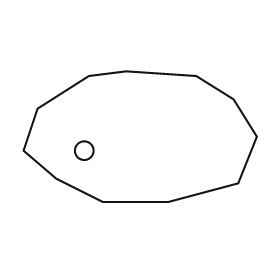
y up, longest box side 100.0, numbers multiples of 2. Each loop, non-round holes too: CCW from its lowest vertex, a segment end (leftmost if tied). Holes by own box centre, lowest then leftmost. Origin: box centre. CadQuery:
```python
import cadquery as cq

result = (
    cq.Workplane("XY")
    .moveTo(-16.0, -28.0)
    .lineTo(12.0, -28.0)
    .lineTo(42.0, -20.0)
    .lineTo(50.0, 0.0)
    .lineTo(40.0, 16.0)
    .lineTo(24.0, 26.0)
    .lineTo(-6.0, 28.0)
    .lineTo(-22.0, 26.0)
    .lineTo(-44.0, 12.0)
    .lineTo(-50.0, -6.0)
    .lineTo(-36.0, -18.0)
    .close()
    .moveTo(-24.0, -6.0)
    .circle(4.0)
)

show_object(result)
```